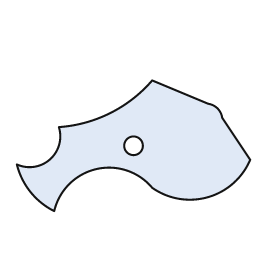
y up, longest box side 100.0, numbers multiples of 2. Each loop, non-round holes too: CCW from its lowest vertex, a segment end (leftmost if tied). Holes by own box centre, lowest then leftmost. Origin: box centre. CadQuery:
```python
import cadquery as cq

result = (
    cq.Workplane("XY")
    .moveTo(-34.0, -28.0)
    .threePointArc((-16.0, -10.0), (8.0, -18.0))
    .threePointArc((32.0, -22.0), (50.0, -6.0))
    .lineTo(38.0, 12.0)
    .threePointArc((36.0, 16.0), (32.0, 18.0))
    .lineTo(8.0, 28.0)
    .threePointArc((-10.0, 14.0), (-32.0, 8.0))
    .threePointArc((-36.0, -6.0), (-50.0, -8.0))
    .threePointArc((-44.0, -20.0), (-34.0, -28.0))
    .close()
    .moveTo(0.0, 0.0)
    .circle(4.0)
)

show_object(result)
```